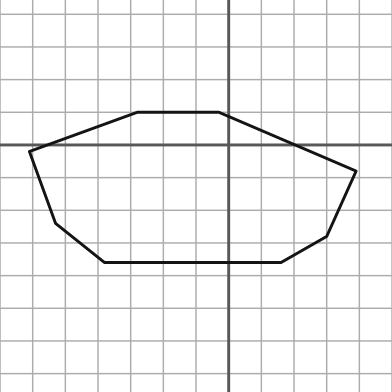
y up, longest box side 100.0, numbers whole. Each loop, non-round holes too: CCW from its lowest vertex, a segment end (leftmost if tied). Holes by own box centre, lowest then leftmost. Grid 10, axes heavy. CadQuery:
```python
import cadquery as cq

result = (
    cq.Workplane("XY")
    .moveTo(-38.0, -36.0)
    .lineTo(16.0, -36.0)
    .lineTo(30.0, -28.0)
    .lineTo(39.0, -8.0)
    .lineTo(-3.0, 10.0)
    .lineTo(-28.0, 10.0)
    .lineTo(-61.0, -2.0)
    .lineTo(-53.0, -24.0)
    .close()
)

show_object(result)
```